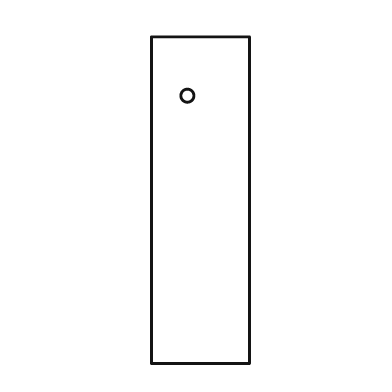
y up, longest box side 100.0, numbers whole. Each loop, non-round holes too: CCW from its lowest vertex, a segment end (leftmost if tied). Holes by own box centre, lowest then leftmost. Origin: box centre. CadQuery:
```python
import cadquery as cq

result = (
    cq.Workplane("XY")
    .moveTo(-15.0, -50.0)
    .lineTo(15.0, -50.0)
    .lineTo(15.0, 50.0)
    .lineTo(-15.0, 50.0)
    .close()
    .moveTo(-4.0, 32.0)
    .circle(2.0)
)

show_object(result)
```